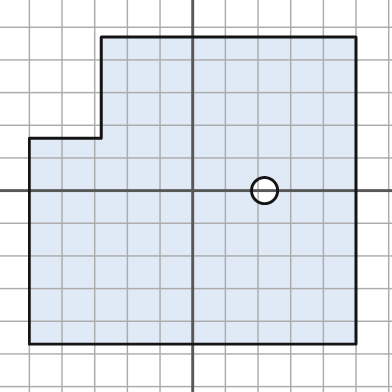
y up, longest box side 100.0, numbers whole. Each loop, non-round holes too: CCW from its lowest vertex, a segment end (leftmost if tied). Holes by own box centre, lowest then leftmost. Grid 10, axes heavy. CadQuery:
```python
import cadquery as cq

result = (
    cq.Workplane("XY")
    .moveTo(-50.0, -47.0)
    .lineTo(50.0, -47.0)
    .lineTo(50.0, 47.0)
    .lineTo(-28.0, 47.0)
    .lineTo(-28.0, 16.0)
    .lineTo(-50.0, 16.0)
    .close()
    .moveTo(22.0, 0.0)
    .circle(4.0)
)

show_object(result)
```